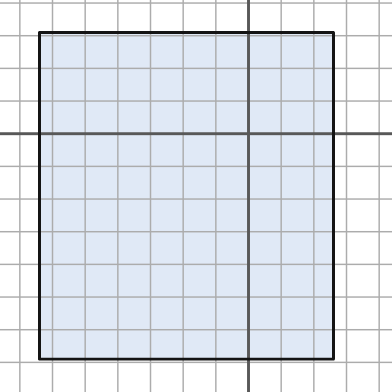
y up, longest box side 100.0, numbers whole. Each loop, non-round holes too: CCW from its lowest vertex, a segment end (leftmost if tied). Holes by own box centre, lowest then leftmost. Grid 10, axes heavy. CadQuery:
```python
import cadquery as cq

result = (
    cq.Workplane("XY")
    .moveTo(-64.0, -69.0)
    .lineTo(26.0, -69.0)
    .lineTo(26.0, 31.0)
    .lineTo(-64.0, 31.0)
    .close()
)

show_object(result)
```